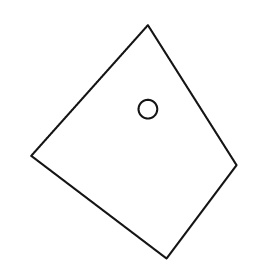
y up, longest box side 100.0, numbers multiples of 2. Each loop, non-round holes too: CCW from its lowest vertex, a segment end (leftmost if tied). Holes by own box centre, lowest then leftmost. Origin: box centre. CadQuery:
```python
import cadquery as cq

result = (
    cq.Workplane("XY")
    .moveTo(14.0, -50.0)
    .lineTo(44.0, -10.0)
    .lineTo(6.0, 50.0)
    .lineTo(-44.0, -6.0)
    .close()
    .moveTo(6.0, 14.0)
    .circle(4.0)
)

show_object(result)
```